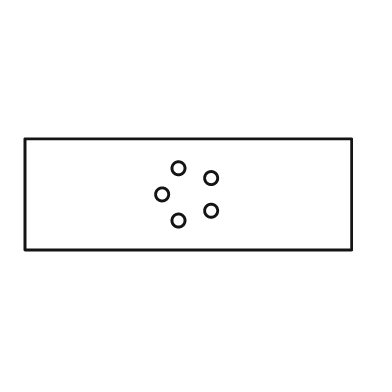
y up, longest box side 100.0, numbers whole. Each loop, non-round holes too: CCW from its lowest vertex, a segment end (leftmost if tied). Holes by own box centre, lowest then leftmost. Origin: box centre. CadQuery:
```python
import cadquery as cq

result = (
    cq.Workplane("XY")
    .moveTo(-50.0, -17.0)
    .lineTo(50.0, -17.0)
    .lineTo(50.0, 17.0)
    .lineTo(-50.0, 17.0)
    .close()
    .moveTo(-3.0, -8.0)
    .circle(2.0)
    .moveTo(7.0, -5.0)
    .circle(2.0)
    .moveTo(-8.0, 0.0)
    .circle(2.0)
    .moveTo(7.0, 5.0)
    .circle(2.0)
    .moveTo(-3.0, 8.0)
    .circle(2.0)
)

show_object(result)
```